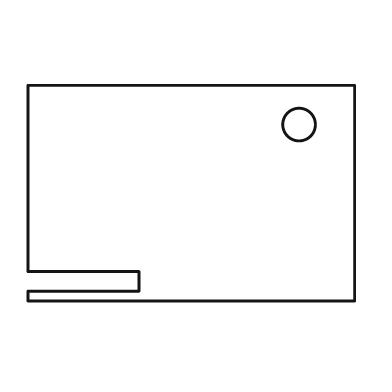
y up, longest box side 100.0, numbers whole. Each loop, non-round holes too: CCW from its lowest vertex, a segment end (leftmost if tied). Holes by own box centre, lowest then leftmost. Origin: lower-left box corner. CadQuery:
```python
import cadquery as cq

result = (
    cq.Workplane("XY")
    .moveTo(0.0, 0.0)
    .lineTo(100.0, 0.0)
    .lineTo(100.0, 66.0)
    .lineTo(0.0, 66.0)
    .lineTo(0.0, 9.0)
    .lineTo(34.0, 9.0)
    .lineTo(34.0, 3.0)
    .lineTo(0.0, 3.0)
    .close()
    .moveTo(83.0, 54.0)
    .circle(5.0)
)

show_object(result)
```